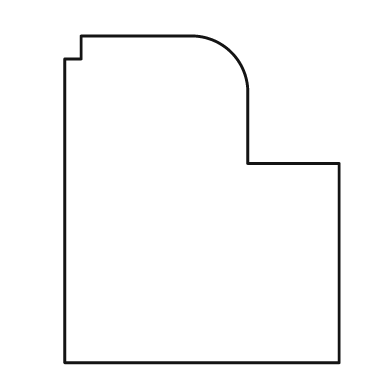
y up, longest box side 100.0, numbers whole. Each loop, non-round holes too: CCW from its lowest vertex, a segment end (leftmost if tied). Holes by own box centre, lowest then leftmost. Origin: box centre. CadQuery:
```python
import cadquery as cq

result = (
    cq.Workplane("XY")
    .moveTo(-42.0, -50.0)
    .lineTo(42.0, -50.0)
    .lineTo(42.0, 11.0)
    .lineTo(14.0, 11.0)
    .lineTo(14.0, 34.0)
    .threePointArc((9.0, 45.0), (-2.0, 50.0))
    .lineTo(-37.0, 50.0)
    .lineTo(-37.0, 43.0)
    .lineTo(-42.0, 43.0)
    .close()
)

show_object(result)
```